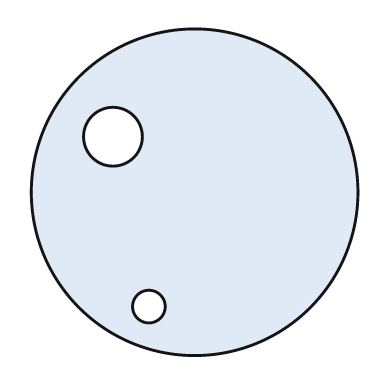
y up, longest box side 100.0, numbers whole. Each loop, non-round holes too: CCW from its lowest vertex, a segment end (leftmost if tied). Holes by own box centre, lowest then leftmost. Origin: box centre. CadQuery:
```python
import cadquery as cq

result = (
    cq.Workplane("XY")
    .moveTo(0.0, 0.0)
    .circle(50.0)
    .moveTo(-14.0, -35.0)
    .circle(5.0)
    .moveTo(-25.0, 17.0)
    .circle(9.0)
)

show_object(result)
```